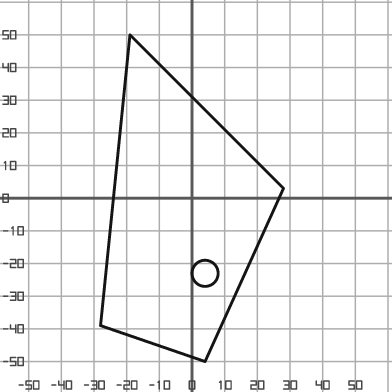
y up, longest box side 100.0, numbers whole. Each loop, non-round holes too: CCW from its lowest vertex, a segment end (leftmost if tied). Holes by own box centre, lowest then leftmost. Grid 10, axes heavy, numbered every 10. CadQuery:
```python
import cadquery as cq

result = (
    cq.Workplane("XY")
    .moveTo(4.0, -50.0)
    .lineTo(28.0, 3.0)
    .lineTo(-19.0, 50.0)
    .lineTo(-28.0, -39.0)
    .close()
    .moveTo(4.0, -23.0)
    .circle(4.0)
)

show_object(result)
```